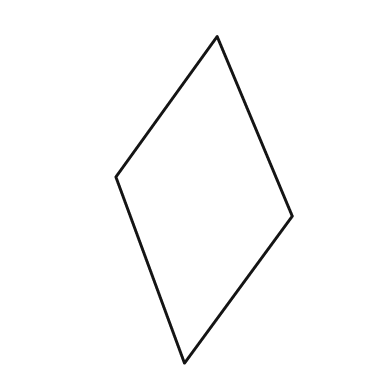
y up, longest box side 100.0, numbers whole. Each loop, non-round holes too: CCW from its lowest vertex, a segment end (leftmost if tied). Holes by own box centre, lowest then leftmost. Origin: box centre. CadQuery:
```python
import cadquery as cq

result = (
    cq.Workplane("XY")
    .moveTo(-6.0, -50.0)
    .lineTo(27.0, -5.0)
    .lineTo(4.0, 50.0)
    .lineTo(-27.0, 7.0)
    .close()
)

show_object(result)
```